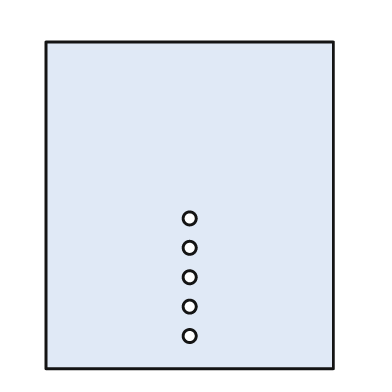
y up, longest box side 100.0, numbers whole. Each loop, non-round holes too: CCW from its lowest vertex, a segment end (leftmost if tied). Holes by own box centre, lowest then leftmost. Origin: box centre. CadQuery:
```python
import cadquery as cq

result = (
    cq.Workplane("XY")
    .moveTo(-44.0, -50.0)
    .lineTo(44.0, -50.0)
    .lineTo(44.0, 50.0)
    .lineTo(-44.0, 50.0)
    .close()
    .moveTo(0.0, -40.0)
    .circle(2.0)
    .moveTo(0.0, -31.0)
    .circle(2.0)
    .moveTo(0.0, -22.0)
    .circle(2.0)
    .moveTo(0.0, -13.0)
    .circle(2.0)
    .moveTo(0.0, -4.0)
    .circle(2.0)
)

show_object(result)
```